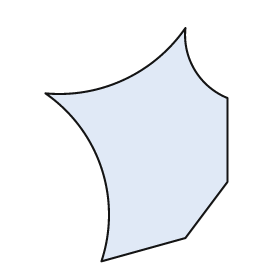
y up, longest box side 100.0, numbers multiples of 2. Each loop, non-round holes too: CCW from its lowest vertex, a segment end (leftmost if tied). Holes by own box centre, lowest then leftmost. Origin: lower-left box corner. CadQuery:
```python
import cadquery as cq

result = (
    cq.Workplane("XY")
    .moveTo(24.0, 0.0)
    .lineTo(60.0, 10.0)
    .lineTo(78.0, 34.0)
    .lineTo(78.0, 70.0)
    .threePointArc((64.0, 82.0), (60.0, 100.0))
    .threePointArc((34.0, 78.0), (0.0, 72.0))
    .threePointArc((24.0, 40.0), (24.0, 0.0))
    .close()
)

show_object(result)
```